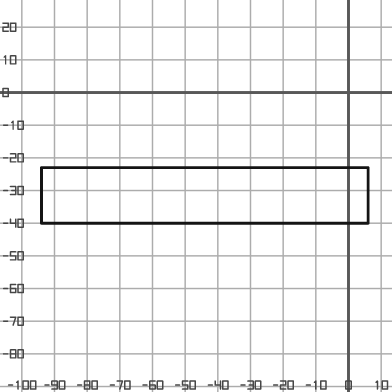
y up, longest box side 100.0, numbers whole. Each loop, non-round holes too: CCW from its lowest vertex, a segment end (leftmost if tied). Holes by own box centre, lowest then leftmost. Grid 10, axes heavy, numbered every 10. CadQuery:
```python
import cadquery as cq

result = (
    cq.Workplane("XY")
    .moveTo(-94.0, -40.0)
    .lineTo(6.0, -40.0)
    .lineTo(6.0, -23.0)
    .lineTo(-94.0, -23.0)
    .close()
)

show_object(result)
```